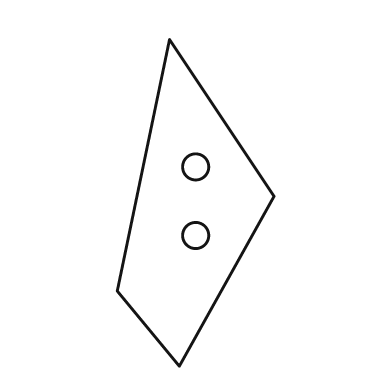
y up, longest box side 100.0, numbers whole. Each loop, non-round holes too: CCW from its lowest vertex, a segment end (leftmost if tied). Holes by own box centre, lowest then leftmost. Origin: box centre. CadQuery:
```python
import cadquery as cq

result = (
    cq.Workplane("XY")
    .moveTo(-5.0, -50.0)
    .lineTo(24.0, 2.0)
    .lineTo(-8.0, 50.0)
    .lineTo(-24.0, -27.0)
    .close()
    .moveTo(0.0, -10.0)
    .circle(4.0)
    .moveTo(0.0, 11.0)
    .circle(4.0)
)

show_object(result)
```